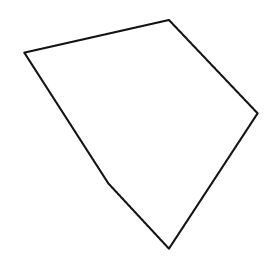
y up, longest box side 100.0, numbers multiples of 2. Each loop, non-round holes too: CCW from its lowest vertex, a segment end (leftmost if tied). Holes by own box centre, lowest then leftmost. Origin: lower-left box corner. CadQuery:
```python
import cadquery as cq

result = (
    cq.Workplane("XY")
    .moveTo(62.0, 0.0)
    .lineTo(100.0, 58.0)
    .lineTo(62.0, 98.0)
    .lineTo(0.0, 84.0)
    .lineTo(36.0, 28.0)
    .close()
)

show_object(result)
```